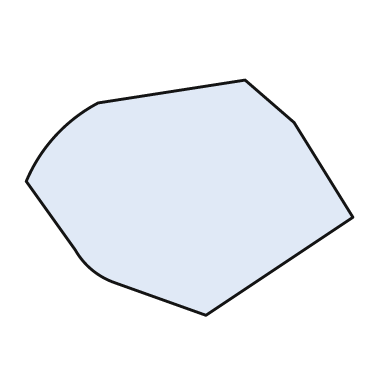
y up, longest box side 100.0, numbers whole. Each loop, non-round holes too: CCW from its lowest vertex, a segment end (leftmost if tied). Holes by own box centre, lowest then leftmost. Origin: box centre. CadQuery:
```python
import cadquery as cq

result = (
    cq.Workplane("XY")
    .moveTo(5.0, -36.0)
    .lineTo(50.0, -6.0)
    .lineTo(32.0, 23.0)
    .lineTo(17.0, 36.0)
    .lineTo(-28.0, 29.0)
    .threePointArc((-41.0, 19.0), (-50.0, 5.0))
    .lineTo(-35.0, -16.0)
    .threePointArc((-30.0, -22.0), (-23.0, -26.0))
    .close()
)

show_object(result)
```